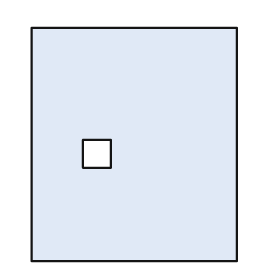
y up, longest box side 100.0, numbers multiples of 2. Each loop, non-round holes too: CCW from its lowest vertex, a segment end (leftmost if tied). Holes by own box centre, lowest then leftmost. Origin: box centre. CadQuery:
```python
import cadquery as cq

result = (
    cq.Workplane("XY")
    .moveTo(-44.0, -50.0)
    .lineTo(44.0, -50.0)
    .lineTo(44.0, 50.0)
    .lineTo(-44.0, 50.0)
    .close()
    .moveTo(-22.0, -10.0)
    .lineTo(-10.0, -10.0)
    .lineTo(-10.0, 2.0)
    .lineTo(-22.0, 2.0)
    .close()
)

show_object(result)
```